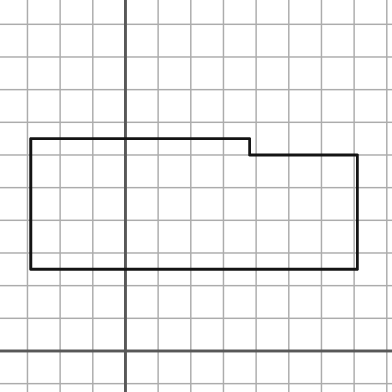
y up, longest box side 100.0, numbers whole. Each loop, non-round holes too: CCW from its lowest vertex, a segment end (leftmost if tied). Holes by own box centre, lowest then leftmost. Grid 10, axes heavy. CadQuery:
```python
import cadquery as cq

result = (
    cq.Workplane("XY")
    .moveTo(-29.0, 25.0)
    .lineTo(71.0, 25.0)
    .lineTo(71.0, 60.0)
    .lineTo(38.0, 60.0)
    .lineTo(38.0, 65.0)
    .lineTo(-29.0, 65.0)
    .close()
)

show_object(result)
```